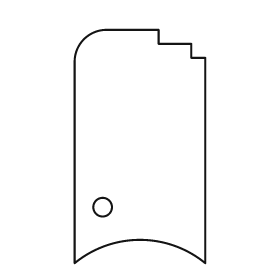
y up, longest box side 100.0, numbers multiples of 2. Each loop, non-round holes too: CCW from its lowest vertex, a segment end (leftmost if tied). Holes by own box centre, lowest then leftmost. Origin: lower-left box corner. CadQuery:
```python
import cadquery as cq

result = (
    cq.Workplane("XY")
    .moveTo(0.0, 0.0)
    .threePointArc((28.0, 10.0), (56.0, 0.0))
    .lineTo(56.0, 88.0)
    .lineTo(50.0, 88.0)
    .lineTo(50.0, 94.0)
    .lineTo(36.0, 94.0)
    .lineTo(36.0, 100.0)
    .lineTo(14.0, 100.0)
    .threePointArc((4.0, 96.0), (0.0, 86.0))
    .close()
    .moveTo(12.0, 24.0)
    .circle(4.0)
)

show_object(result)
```